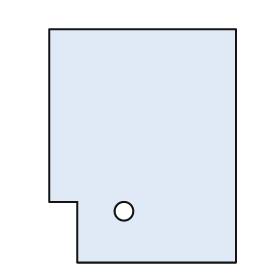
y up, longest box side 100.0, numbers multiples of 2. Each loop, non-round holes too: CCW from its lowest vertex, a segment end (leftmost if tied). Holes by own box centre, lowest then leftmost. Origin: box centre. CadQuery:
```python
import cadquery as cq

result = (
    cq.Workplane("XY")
    .moveTo(-28.0, -50.0)
    .lineTo(40.0, -50.0)
    .lineTo(40.0, 50.0)
    .lineTo(-40.0, 50.0)
    .lineTo(-40.0, -24.0)
    .lineTo(-28.0, -24.0)
    .close()
    .moveTo(-8.0, -28.0)
    .circle(4.0)
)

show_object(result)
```